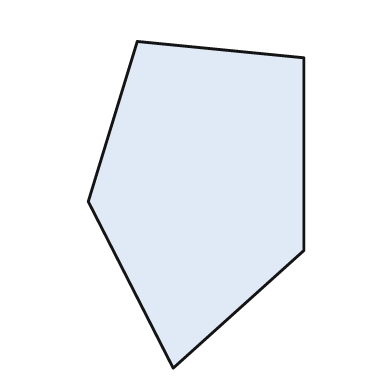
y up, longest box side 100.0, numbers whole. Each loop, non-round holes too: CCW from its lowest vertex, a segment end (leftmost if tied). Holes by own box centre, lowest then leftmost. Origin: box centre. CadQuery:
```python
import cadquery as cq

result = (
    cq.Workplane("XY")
    .moveTo(-7.0, -50.0)
    .lineTo(33.0, -14.0)
    .lineTo(33.0, 45.0)
    .lineTo(-18.0, 50.0)
    .lineTo(-33.0, 1.0)
    .close()
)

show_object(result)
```